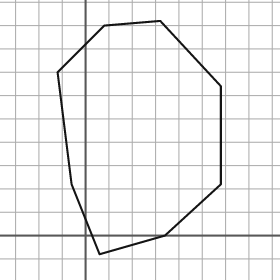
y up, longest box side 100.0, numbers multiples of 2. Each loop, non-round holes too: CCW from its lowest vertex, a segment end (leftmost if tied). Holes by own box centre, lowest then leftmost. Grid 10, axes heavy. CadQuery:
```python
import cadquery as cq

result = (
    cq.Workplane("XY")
    .moveTo(6.0, -8.0)
    .lineTo(34.0, 0.0)
    .lineTo(58.0, 22.0)
    .lineTo(58.0, 64.0)
    .lineTo(32.0, 92.0)
    .lineTo(8.0, 90.0)
    .lineTo(-12.0, 70.0)
    .lineTo(-6.0, 22.0)
    .close()
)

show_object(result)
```